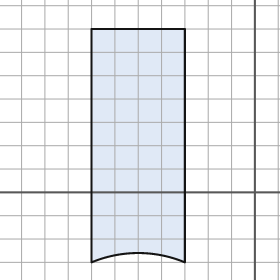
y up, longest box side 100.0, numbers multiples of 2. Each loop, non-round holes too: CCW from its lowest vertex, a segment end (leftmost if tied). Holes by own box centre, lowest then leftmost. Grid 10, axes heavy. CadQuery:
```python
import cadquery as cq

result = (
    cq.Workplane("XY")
    .moveTo(-70.0, -30.0)
    .threePointArc((-50.0, -26.0), (-30.0, -30.0))
    .lineTo(-30.0, 70.0)
    .lineTo(-70.0, 70.0)
    .close()
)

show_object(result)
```